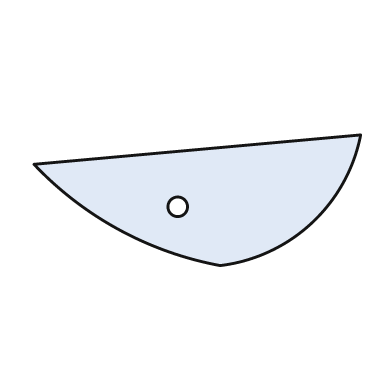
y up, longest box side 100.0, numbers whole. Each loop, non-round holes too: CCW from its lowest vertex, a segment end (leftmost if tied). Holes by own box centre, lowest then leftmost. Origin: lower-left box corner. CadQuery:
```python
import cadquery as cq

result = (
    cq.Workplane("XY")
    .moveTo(57.0, 0.0)
    .threePointArc((85.0, 13.0), (100.0, 40.0))
    .lineTo(0.0, 31.0)
    .threePointArc((26.0, 11.0), (57.0, 0.0))
    .close()
    .moveTo(44.0, 18.0)
    .circle(3.0)
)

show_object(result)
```